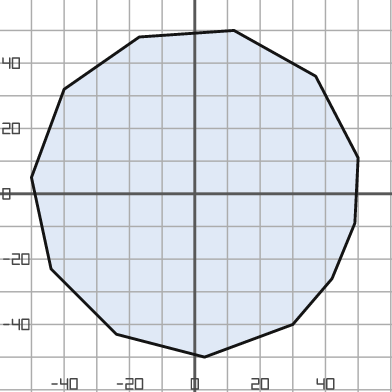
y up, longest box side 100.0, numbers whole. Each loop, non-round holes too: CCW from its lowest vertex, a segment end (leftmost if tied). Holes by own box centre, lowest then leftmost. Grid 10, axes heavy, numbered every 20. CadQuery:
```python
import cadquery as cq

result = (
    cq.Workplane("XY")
    .moveTo(3.0, -50.0)
    .lineTo(30.0, -40.0)
    .lineTo(42.0, -26.0)
    .lineTo(49.0, -9.0)
    .lineTo(50.0, 11.0)
    .lineTo(37.0, 36.0)
    .lineTo(12.0, 50.0)
    .lineTo(-17.0, 48.0)
    .lineTo(-40.0, 32.0)
    .lineTo(-50.0, 5.0)
    .lineTo(-44.0, -23.0)
    .lineTo(-24.0, -43.0)
    .close()
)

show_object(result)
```